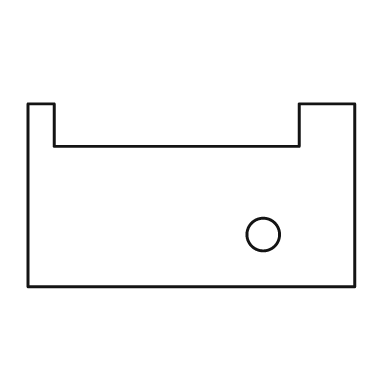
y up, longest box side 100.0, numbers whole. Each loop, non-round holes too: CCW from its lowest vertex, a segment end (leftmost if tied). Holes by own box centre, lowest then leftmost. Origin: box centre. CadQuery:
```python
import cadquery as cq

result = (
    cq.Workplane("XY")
    .moveTo(-50.0, -28.0)
    .lineTo(50.0, -28.0)
    .lineTo(50.0, 28.0)
    .lineTo(33.0, 28.0)
    .lineTo(33.0, 15.0)
    .lineTo(-42.0, 15.0)
    .lineTo(-42.0, 28.0)
    .lineTo(-50.0, 28.0)
    .close()
    .moveTo(22.0, -12.0)
    .circle(5.0)
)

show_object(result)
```